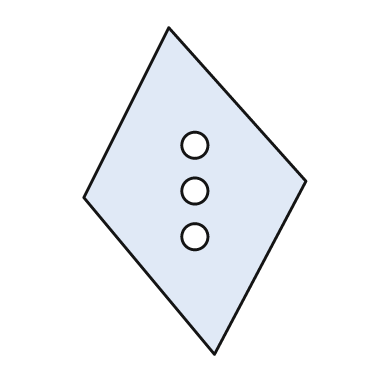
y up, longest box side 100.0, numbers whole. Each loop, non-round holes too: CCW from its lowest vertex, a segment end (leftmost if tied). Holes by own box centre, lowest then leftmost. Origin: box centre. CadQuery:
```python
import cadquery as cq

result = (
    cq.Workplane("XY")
    .moveTo(6.0, -50.0)
    .lineTo(34.0, 3.0)
    .lineTo(-8.0, 50.0)
    .lineTo(-34.0, -2.0)
    .close()
    .moveTo(0.0, -14.0)
    .circle(4.0)
    .moveTo(0.0, 0.0)
    .circle(4.0)
    .moveTo(0.0, 14.0)
    .circle(4.0)
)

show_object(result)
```